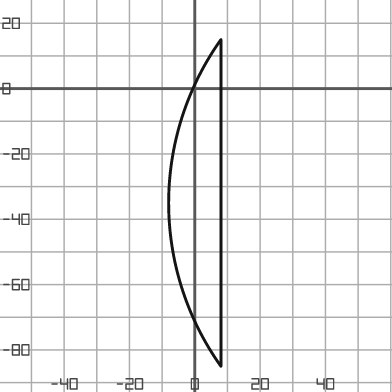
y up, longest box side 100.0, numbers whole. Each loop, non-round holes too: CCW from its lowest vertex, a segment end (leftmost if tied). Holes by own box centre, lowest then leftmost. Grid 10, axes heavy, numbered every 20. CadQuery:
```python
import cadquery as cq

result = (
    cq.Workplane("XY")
    .moveTo(8.0, -85.0)
    .lineTo(8.0, 15.0)
    .threePointArc((-8.0, -35.0), (8.0, -85.0))
    .close()
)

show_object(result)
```